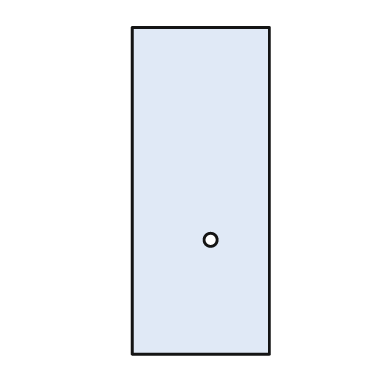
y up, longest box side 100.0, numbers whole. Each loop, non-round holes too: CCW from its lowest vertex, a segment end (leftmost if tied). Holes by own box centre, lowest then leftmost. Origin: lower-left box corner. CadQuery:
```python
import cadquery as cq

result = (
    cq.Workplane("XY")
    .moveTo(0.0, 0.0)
    .lineTo(42.0, 0.0)
    .lineTo(42.0, 100.0)
    .lineTo(0.0, 100.0)
    .close()
    .moveTo(24.0, 35.0)
    .circle(2.0)
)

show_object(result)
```